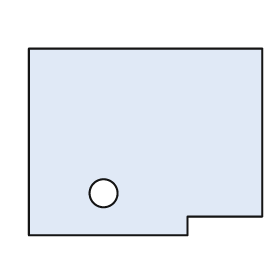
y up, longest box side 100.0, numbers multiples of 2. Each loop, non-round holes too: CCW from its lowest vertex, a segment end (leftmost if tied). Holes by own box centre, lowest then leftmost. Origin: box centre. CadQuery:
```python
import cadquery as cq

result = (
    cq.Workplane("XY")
    .moveTo(-50.0, -40.0)
    .lineTo(18.0, -40.0)
    .lineTo(18.0, -32.0)
    .lineTo(50.0, -32.0)
    .lineTo(50.0, 40.0)
    .lineTo(-50.0, 40.0)
    .close()
    .moveTo(-18.0, -22.0)
    .circle(6.0)
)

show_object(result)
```